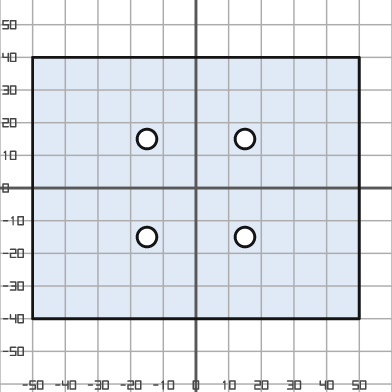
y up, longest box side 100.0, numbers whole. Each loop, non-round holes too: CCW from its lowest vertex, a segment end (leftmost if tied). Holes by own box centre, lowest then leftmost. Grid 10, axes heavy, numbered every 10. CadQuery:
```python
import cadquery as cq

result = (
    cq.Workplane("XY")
    .moveTo(-50.0, -40.0)
    .lineTo(50.0, -40.0)
    .lineTo(50.0, 40.0)
    .lineTo(-50.0, 40.0)
    .close()
    .moveTo(-15.0, -15.0)
    .circle(3.0)
    .moveTo(15.0, -15.0)
    .circle(3.0)
    .moveTo(-15.0, 15.0)
    .circle(3.0)
    .moveTo(15.0, 15.0)
    .circle(3.0)
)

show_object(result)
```